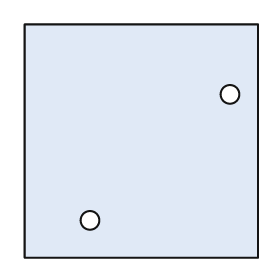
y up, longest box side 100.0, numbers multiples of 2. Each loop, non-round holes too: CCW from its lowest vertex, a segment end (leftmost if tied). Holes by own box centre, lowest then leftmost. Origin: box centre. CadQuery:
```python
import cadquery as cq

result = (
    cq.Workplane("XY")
    .moveTo(-50.0, -50.0)
    .lineTo(50.0, -50.0)
    .lineTo(50.0, 50.0)
    .lineTo(-50.0, 50.0)
    .close()
    .moveTo(-22.0, -34.0)
    .circle(4.0)
    .moveTo(38.0, 20.0)
    .circle(4.0)
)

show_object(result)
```